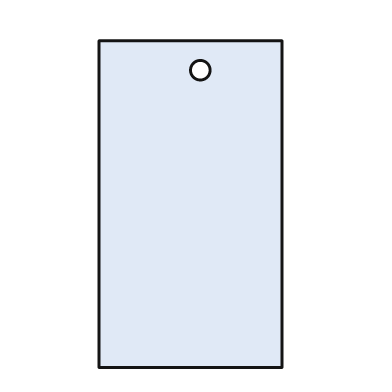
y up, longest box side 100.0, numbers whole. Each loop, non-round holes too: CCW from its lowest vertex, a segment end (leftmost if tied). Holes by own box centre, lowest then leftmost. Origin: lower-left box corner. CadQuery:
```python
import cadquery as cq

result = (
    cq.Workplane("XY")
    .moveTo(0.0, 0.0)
    .lineTo(56.0, 0.0)
    .lineTo(56.0, 100.0)
    .lineTo(0.0, 100.0)
    .close()
    .moveTo(31.0, 91.0)
    .circle(3.0)
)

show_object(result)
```